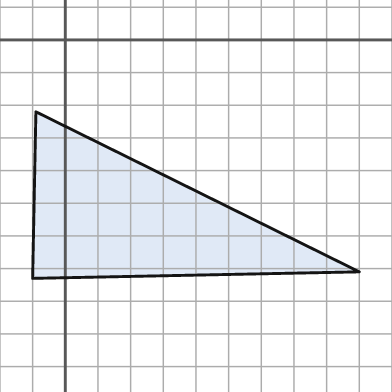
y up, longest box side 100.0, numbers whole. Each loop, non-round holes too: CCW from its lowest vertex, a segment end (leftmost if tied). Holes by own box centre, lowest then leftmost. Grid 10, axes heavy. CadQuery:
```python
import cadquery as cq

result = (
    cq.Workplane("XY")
    .moveTo(-10.0, -73.0)
    .lineTo(90.0, -71.0)
    .lineTo(-9.0, -22.0)
    .close()
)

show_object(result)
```